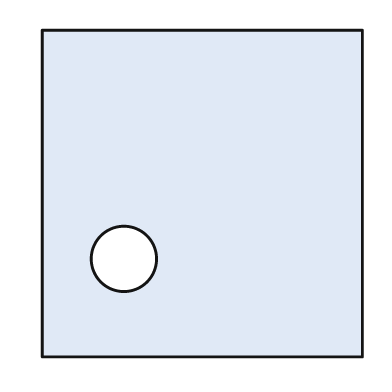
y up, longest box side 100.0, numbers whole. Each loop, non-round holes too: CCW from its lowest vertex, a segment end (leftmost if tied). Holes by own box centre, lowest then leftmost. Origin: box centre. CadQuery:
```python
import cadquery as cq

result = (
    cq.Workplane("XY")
    .moveTo(-49.0, -50.0)
    .lineTo(49.0, -50.0)
    .lineTo(49.0, 50.0)
    .lineTo(-49.0, 50.0)
    .close()
    .moveTo(-24.0, -20.0)
    .circle(10.0)
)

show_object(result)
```